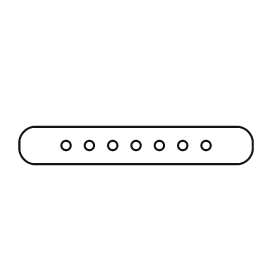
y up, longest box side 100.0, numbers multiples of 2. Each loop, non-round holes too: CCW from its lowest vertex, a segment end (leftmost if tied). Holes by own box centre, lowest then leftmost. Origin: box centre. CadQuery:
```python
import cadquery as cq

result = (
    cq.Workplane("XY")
    .moveTo(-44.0, -8.0)
    .lineTo(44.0, -8.0)
    .threePointArc((48.0, -6.0), (50.0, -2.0))
    .lineTo(50.0, 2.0)
    .threePointArc((48.0, 6.0), (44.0, 8.0))
    .lineTo(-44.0, 8.0)
    .threePointArc((-48.0, 6.0), (-50.0, 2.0))
    .lineTo(-50.0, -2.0)
    .threePointArc((-48.0, -6.0), (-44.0, -8.0))
    .close()
    .moveTo(-30.0, 0.0)
    .circle(2.0)
    .moveTo(-20.0, 0.0)
    .circle(2.0)
    .moveTo(-10.0, 0.0)
    .circle(2.0)
    .moveTo(0.0, 0.0)
    .circle(2.0)
    .moveTo(10.0, 0.0)
    .circle(2.0)
    .moveTo(20.0, 0.0)
    .circle(2.0)
    .moveTo(30.0, 0.0)
    .circle(2.0)
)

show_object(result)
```